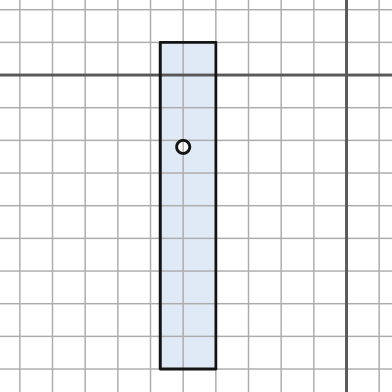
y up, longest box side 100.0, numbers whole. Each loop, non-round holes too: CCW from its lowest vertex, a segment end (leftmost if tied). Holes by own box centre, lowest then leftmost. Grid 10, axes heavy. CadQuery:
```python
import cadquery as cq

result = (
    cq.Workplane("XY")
    .moveTo(-57.0, -90.0)
    .lineTo(-40.0, -90.0)
    .lineTo(-40.0, 10.0)
    .lineTo(-57.0, 10.0)
    .close()
    .moveTo(-50.0, -22.0)
    .circle(2.0)
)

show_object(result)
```